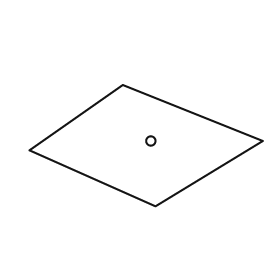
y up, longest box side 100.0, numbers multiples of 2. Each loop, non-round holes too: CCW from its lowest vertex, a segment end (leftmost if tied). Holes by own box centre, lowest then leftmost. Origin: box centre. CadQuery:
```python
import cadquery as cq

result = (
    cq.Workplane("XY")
    .moveTo(4.0, -26.0)
    .lineTo(50.0, 2.0)
    .lineTo(-10.0, 26.0)
    .lineTo(-50.0, -2.0)
    .close()
    .moveTo(2.0, 2.0)
    .circle(2.0)
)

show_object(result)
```